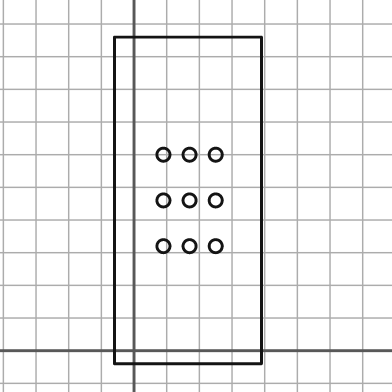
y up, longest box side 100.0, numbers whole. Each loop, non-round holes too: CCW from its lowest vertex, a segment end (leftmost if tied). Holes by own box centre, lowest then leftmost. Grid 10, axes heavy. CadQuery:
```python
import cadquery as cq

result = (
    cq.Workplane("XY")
    .moveTo(-6.0, -4.0)
    .lineTo(39.0, -4.0)
    .lineTo(39.0, 96.0)
    .lineTo(-6.0, 96.0)
    .close()
    .moveTo(9.0, 32.0)
    .circle(2.0)
    .moveTo(17.0, 32.0)
    .circle(2.0)
    .moveTo(25.0, 32.0)
    .circle(2.0)
    .moveTo(9.0, 46.0)
    .circle(2.0)
    .moveTo(17.0, 46.0)
    .circle(2.0)
    .moveTo(25.0, 46.0)
    .circle(2.0)
    .moveTo(9.0, 60.0)
    .circle(2.0)
    .moveTo(17.0, 60.0)
    .circle(2.0)
    .moveTo(25.0, 60.0)
    .circle(2.0)
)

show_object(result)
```